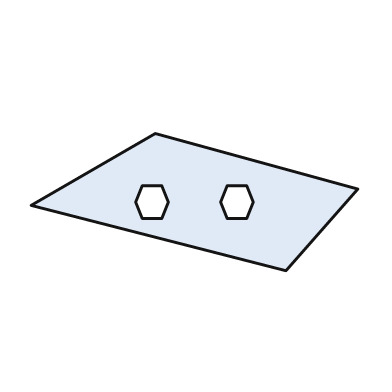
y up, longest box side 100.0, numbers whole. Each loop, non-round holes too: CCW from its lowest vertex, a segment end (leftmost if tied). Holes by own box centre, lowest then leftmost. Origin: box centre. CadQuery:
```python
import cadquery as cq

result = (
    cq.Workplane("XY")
    .moveTo(28.0, -21.0)
    .lineTo(50.0, 4.0)
    .lineTo(-12.0, 21.0)
    .lineTo(-50.0, -1.0)
    .close()
    .moveTo(-16.0, -5.0)
    .lineTo(-10.0, -5.0)
    .lineTo(-8.0, 0.0)
    .lineTo(-10.0, 5.0)
    .lineTo(-16.0, 5.0)
    .lineTo(-18.0, 0.0)
    .close()
    .moveTo(10.0, -5.0)
    .lineTo(16.0, -5.0)
    .lineTo(18.0, 0.0)
    .lineTo(16.0, 5.0)
    .lineTo(10.0, 5.0)
    .lineTo(8.0, 0.0)
    .close()
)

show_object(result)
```